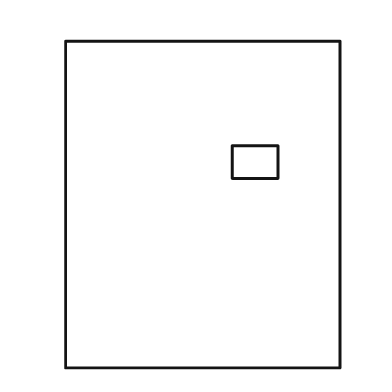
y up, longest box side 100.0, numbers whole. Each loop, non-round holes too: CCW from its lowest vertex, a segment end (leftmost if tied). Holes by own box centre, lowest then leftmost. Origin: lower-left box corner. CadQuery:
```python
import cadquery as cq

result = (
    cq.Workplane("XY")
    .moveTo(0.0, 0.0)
    .lineTo(84.0, 0.0)
    .lineTo(84.0, 100.0)
    .lineTo(0.0, 100.0)
    .close()
    .moveTo(51.0, 58.0)
    .lineTo(65.0, 58.0)
    .lineTo(65.0, 68.0)
    .lineTo(51.0, 68.0)
    .close()
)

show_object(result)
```